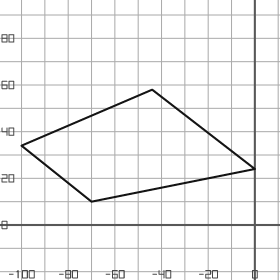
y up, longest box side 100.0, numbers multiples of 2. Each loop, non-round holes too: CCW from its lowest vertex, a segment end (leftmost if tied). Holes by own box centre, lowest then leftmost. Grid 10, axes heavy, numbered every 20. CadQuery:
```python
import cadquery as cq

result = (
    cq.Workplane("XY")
    .moveTo(-70.0, 10.0)
    .lineTo(0.0, 24.0)
    .lineTo(-44.0, 58.0)
    .lineTo(-100.0, 34.0)
    .close()
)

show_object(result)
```